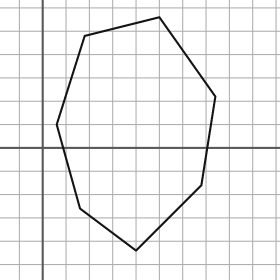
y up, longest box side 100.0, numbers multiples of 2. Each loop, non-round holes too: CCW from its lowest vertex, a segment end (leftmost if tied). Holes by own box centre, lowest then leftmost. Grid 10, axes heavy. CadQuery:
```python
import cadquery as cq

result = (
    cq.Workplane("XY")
    .moveTo(40.0, -44.0)
    .lineTo(68.0, -16.0)
    .lineTo(74.0, 22.0)
    .lineTo(50.0, 56.0)
    .lineTo(18.0, 48.0)
    .lineTo(6.0, 10.0)
    .lineTo(16.0, -26.0)
    .close()
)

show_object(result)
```